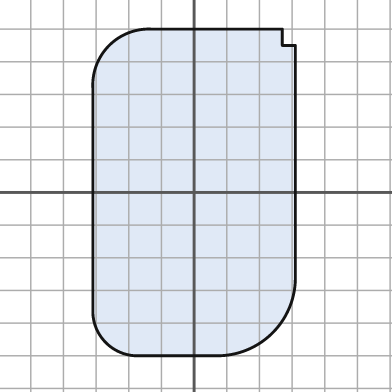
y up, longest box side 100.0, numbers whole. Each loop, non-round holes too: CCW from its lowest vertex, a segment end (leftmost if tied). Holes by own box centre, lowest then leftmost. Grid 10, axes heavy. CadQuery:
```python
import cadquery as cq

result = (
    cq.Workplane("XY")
    .moveTo(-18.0, -50.0)
    .lineTo(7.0, -50.0)
    .threePointArc((24.0, -43.0), (31.0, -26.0))
    .lineTo(31.0, 45.0)
    .lineTo(27.0, 45.0)
    .lineTo(27.0, 50.0)
    .lineTo(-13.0, 50.0)
    .threePointArc((-26.0, 45.0), (-31.0, 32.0))
    .lineTo(-31.0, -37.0)
    .threePointArc((-27.0, -46.0), (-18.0, -50.0))
    .close()
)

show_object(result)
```